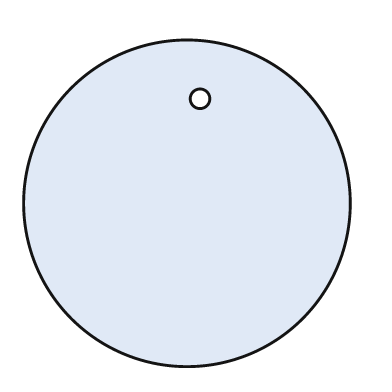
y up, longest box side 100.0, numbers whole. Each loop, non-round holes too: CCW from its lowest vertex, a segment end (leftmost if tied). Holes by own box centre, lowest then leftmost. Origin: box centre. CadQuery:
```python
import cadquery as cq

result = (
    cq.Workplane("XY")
    .moveTo(0.0, 0.0)
    .circle(50.0)
    .moveTo(4.0, 32.0)
    .circle(3.0)
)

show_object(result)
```